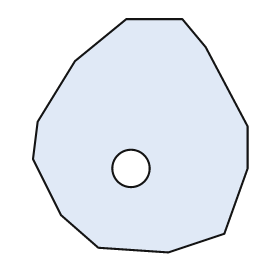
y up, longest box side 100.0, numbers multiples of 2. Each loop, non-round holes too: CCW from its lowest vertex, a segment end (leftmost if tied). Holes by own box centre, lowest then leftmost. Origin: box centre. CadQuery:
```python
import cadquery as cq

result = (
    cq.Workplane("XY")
    .moveTo(12.0, -50.0)
    .lineTo(36.0, -42.0)
    .lineTo(46.0, -14.0)
    .lineTo(46.0, 4.0)
    .lineTo(28.0, 38.0)
    .lineTo(18.0, 50.0)
    .lineTo(-6.0, 50.0)
    .lineTo(-28.0, 32.0)
    .lineTo(-44.0, 6.0)
    .lineTo(-46.0, -10.0)
    .lineTo(-34.0, -34.0)
    .lineTo(-18.0, -48.0)
    .close()
    .moveTo(-4.0, -14.0)
    .circle(8.0)
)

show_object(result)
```